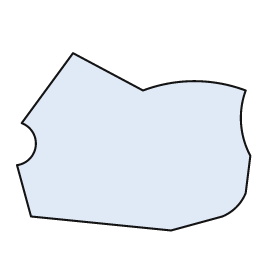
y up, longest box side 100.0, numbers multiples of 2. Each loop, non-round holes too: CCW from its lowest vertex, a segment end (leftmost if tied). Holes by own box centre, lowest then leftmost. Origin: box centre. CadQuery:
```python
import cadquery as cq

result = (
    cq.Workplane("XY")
    .moveTo(16.0, -38.0)
    .lineTo(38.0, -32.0)
    .threePointArc((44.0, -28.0), (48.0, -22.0))
    .lineTo(50.0, -6.0)
    .threePointArc((46.0, 8.0), (48.0, 22.0))
    .threePointArc((26.0, 26.0), (4.0, 22.0))
    .lineTo(-26.0, 38.0)
    .lineTo(-48.0, 8.0)
    .threePointArc((-42.0, -2.0), (-50.0, -10.0))
    .lineTo(-44.0, -32.0)
    .close()
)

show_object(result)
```